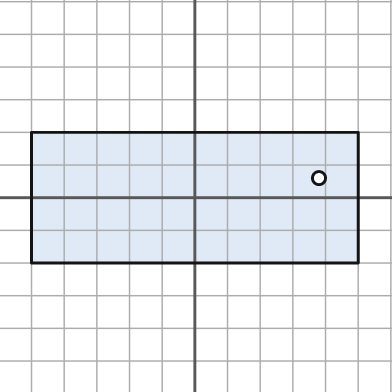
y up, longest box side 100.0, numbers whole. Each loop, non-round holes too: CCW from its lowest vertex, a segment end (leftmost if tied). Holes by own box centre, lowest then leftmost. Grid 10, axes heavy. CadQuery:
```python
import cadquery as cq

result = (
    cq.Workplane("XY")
    .moveTo(-50.0, -20.0)
    .lineTo(50.0, -20.0)
    .lineTo(50.0, 20.0)
    .lineTo(-50.0, 20.0)
    .close()
    .moveTo(38.0, 6.0)
    .circle(2.0)
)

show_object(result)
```